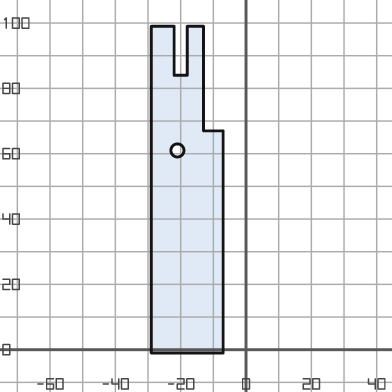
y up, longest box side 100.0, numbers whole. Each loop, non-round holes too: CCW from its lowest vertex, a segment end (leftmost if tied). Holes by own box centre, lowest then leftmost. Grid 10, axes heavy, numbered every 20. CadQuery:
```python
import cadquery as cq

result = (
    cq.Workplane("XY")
    .moveTo(-29.0, -1.0)
    .lineTo(-7.0, -1.0)
    .lineTo(-7.0, 67.0)
    .lineTo(-13.0, 67.0)
    .lineTo(-13.0, 99.0)
    .lineTo(-18.0, 99.0)
    .lineTo(-18.0, 84.0)
    .lineTo(-22.0, 84.0)
    .lineTo(-22.0, 99.0)
    .lineTo(-29.0, 99.0)
    .close()
    .moveTo(-21.0, 61.0)
    .circle(2.0)
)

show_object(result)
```